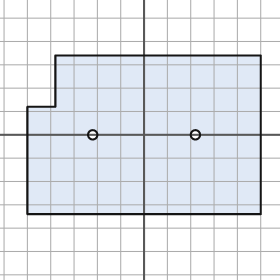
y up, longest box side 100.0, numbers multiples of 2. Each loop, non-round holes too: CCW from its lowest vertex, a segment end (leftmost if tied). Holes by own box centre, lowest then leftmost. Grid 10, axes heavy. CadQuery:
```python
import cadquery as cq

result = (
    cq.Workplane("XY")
    .moveTo(-50.0, -34.0)
    .lineTo(50.0, -34.0)
    .lineTo(50.0, 34.0)
    .lineTo(-38.0, 34.0)
    .lineTo(-38.0, 12.0)
    .lineTo(-50.0, 12.0)
    .close()
    .moveTo(-22.0, 0.0)
    .circle(2.0)
    .moveTo(22.0, 0.0)
    .circle(2.0)
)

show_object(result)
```